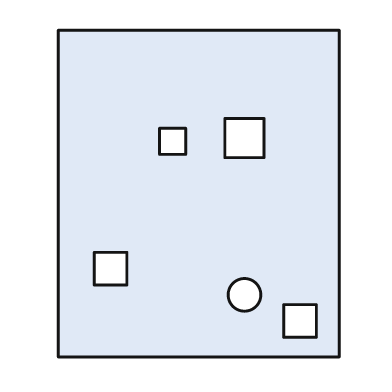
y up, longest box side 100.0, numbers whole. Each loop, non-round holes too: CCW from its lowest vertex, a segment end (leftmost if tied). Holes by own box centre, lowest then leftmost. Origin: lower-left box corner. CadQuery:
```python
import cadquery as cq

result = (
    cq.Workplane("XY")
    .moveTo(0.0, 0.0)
    .lineTo(86.0, 0.0)
    .lineTo(86.0, 100.0)
    .lineTo(0.0, 100.0)
    .close()
    .moveTo(69.0, 6.0)
    .lineTo(79.0, 6.0)
    .lineTo(79.0, 16.0)
    .lineTo(69.0, 16.0)
    .close()
    .moveTo(57.0, 19.0)
    .circle(5.0)
    .moveTo(11.0, 22.0)
    .lineTo(21.0, 22.0)
    .lineTo(21.0, 32.0)
    .lineTo(11.0, 32.0)
    .close()
    .moveTo(31.0, 62.0)
    .lineTo(39.0, 62.0)
    .lineTo(39.0, 70.0)
    .lineTo(31.0, 70.0)
    .close()
    .moveTo(51.0, 61.0)
    .lineTo(63.0, 61.0)
    .lineTo(63.0, 73.0)
    .lineTo(51.0, 73.0)
    .close()
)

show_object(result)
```